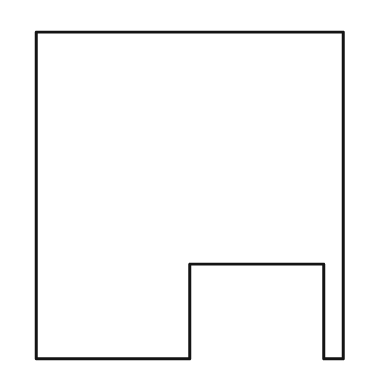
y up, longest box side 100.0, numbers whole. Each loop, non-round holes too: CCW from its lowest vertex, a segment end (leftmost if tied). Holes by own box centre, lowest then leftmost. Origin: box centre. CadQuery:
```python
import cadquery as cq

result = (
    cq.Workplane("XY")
    .moveTo(-47.0, -50.0)
    .lineTo(0.0, -50.0)
    .lineTo(0.0, -21.0)
    .lineTo(41.0, -21.0)
    .lineTo(41.0, -50.0)
    .lineTo(47.0, -50.0)
    .lineTo(47.0, 50.0)
    .lineTo(-47.0, 50.0)
    .close()
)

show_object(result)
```